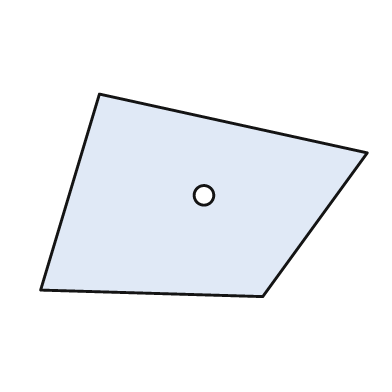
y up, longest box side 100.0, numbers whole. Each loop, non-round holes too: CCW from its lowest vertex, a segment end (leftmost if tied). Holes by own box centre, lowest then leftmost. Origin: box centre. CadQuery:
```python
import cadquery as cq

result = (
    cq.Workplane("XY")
    .moveTo(18.0, -31.0)
    .lineTo(50.0, 13.0)
    .lineTo(-32.0, 31.0)
    .lineTo(-50.0, -29.0)
    .close()
    .moveTo(0.0, 0.0)
    .circle(3.0)
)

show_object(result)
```